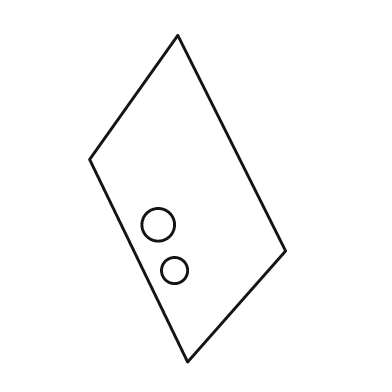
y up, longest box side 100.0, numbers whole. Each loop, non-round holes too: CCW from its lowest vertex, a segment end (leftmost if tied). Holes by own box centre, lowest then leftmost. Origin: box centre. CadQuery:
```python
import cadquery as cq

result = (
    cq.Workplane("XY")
    .moveTo(0.0, -50.0)
    .lineTo(30.0, -16.0)
    .lineTo(-3.0, 50.0)
    .lineTo(-30.0, 12.0)
    .close()
    .moveTo(-4.0, -22.0)
    .circle(4.0)
    .moveTo(-9.0, -8.0)
    .circle(5.0)
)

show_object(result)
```